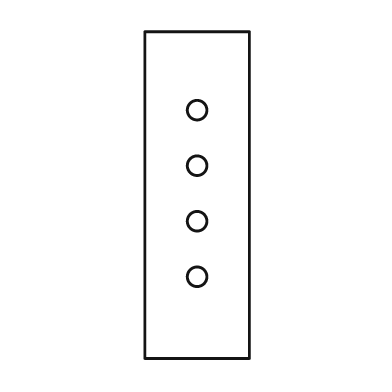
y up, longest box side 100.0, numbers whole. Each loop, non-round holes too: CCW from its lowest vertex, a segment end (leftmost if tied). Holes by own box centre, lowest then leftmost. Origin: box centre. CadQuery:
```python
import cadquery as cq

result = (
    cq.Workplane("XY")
    .moveTo(-16.0, -50.0)
    .lineTo(16.0, -50.0)
    .lineTo(16.0, 50.0)
    .lineTo(-16.0, 50.0)
    .close()
    .moveTo(0.0, -25.0)
    .circle(3.0)
    .moveTo(0.0, -8.0)
    .circle(3.0)
    .moveTo(0.0, 9.0)
    .circle(3.0)
    .moveTo(0.0, 26.0)
    .circle(3.0)
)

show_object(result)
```